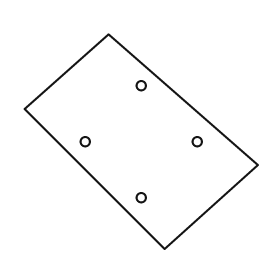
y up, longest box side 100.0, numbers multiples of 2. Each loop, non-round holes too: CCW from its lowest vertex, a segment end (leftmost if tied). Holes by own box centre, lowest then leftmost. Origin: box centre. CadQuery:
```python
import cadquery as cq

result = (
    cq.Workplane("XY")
    .moveTo(10.0, -46.0)
    .lineTo(50.0, -10.0)
    .lineTo(-14.0, 46.0)
    .lineTo(-50.0, 14.0)
    .close()
    .moveTo(0.0, -24.0)
    .circle(2.0)
    .moveTo(-24.0, 0.0)
    .circle(2.0)
    .moveTo(24.0, 0.0)
    .circle(2.0)
    .moveTo(0.0, 24.0)
    .circle(2.0)
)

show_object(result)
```